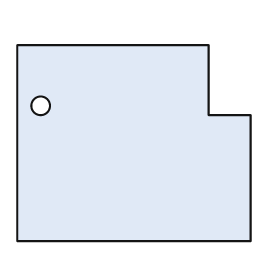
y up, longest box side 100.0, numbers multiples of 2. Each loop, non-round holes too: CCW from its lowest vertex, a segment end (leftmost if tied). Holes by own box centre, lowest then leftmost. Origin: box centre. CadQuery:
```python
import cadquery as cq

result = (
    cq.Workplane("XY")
    .moveTo(-50.0, -42.0)
    .lineTo(50.0, -42.0)
    .lineTo(50.0, 12.0)
    .lineTo(32.0, 12.0)
    .lineTo(32.0, 42.0)
    .lineTo(-50.0, 42.0)
    .close()
    .moveTo(-40.0, 16.0)
    .circle(4.0)
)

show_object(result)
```